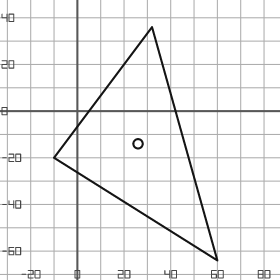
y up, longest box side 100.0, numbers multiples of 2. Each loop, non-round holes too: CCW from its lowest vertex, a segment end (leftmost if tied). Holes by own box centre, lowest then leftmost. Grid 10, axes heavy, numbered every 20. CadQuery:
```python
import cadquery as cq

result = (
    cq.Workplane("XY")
    .moveTo(60.0, -64.0)
    .lineTo(32.0, 36.0)
    .lineTo(-10.0, -20.0)
    .close()
    .moveTo(26.0, -14.0)
    .circle(2.0)
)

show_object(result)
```